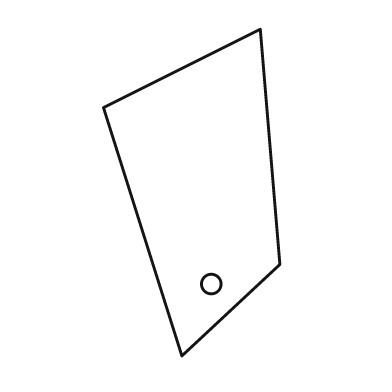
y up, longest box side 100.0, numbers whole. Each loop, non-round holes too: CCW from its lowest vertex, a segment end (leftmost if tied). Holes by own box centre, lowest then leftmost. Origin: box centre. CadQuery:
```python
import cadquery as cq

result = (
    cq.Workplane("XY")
    .moveTo(-3.0, -50.0)
    .lineTo(27.0, -22.0)
    .lineTo(21.0, 50.0)
    .lineTo(-27.0, 26.0)
    .close()
    .moveTo(6.0, -28.0)
    .circle(3.0)
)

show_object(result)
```